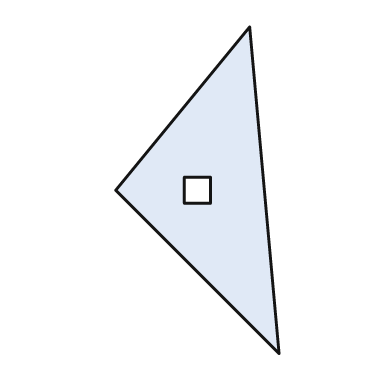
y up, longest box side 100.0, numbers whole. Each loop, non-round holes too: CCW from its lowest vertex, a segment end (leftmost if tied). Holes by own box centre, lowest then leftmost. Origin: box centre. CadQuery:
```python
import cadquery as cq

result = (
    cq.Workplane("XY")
    .moveTo(25.0, -50.0)
    .lineTo(16.0, 50.0)
    .lineTo(-25.0, 0.0)
    .close()
    .moveTo(-4.0, -4.0)
    .lineTo(4.0, -4.0)
    .lineTo(4.0, 4.0)
    .lineTo(-4.0, 4.0)
    .close()
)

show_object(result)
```